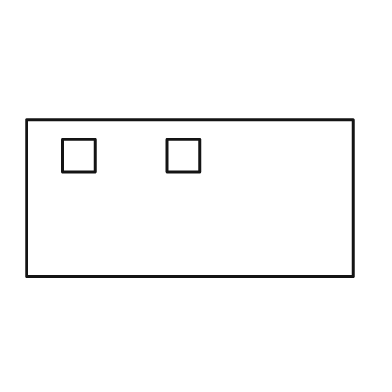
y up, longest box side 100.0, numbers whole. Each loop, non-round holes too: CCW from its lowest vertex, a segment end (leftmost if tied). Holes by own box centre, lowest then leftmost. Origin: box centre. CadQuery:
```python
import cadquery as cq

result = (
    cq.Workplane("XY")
    .moveTo(-50.0, -24.0)
    .lineTo(50.0, -24.0)
    .lineTo(50.0, 24.0)
    .lineTo(-50.0, 24.0)
    .close()
    .moveTo(-39.0, 8.0)
    .lineTo(-29.0, 8.0)
    .lineTo(-29.0, 18.0)
    .lineTo(-39.0, 18.0)
    .close()
    .moveTo(-7.0, 8.0)
    .lineTo(3.0, 8.0)
    .lineTo(3.0, 18.0)
    .lineTo(-7.0, 18.0)
    .close()
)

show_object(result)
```